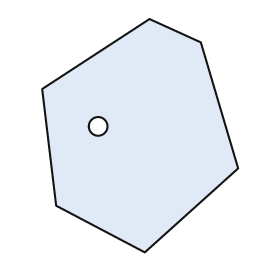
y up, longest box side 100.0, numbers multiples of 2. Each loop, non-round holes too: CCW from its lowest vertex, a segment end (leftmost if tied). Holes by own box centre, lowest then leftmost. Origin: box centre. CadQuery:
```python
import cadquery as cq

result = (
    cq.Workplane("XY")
    .moveTo(2.0, -50.0)
    .lineTo(42.0, -14.0)
    .lineTo(26.0, 40.0)
    .lineTo(4.0, 50.0)
    .lineTo(-42.0, 20.0)
    .lineTo(-36.0, -30.0)
    .close()
    .moveTo(-18.0, 4.0)
    .circle(4.0)
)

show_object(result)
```